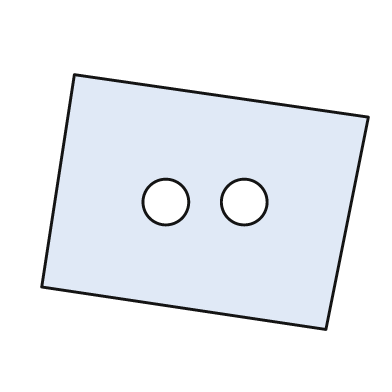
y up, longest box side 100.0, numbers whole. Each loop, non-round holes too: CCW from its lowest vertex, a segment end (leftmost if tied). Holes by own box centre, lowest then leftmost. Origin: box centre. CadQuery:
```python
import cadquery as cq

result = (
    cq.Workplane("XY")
    .moveTo(37.0, -39.0)
    .lineTo(50.0, 26.0)
    .lineTo(-40.0, 39.0)
    .lineTo(-50.0, -26.0)
    .close()
    .moveTo(-12.0, 0.0)
    .circle(7.0)
    .moveTo(12.0, 0.0)
    .circle(7.0)
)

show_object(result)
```